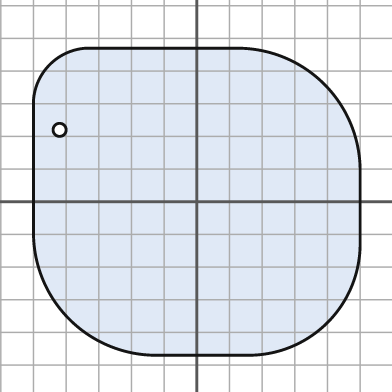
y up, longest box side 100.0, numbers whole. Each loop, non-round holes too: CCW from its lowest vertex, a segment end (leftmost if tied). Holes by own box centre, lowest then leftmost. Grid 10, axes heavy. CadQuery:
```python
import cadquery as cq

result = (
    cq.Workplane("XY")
    .moveTo(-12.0, -47.0)
    .lineTo(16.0, -47.0)
    .threePointArc((40.0, -37.0), (50.0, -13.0))
    .lineTo(50.0, 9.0)
    .threePointArc((39.0, 36.0), (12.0, 47.0))
    .lineTo(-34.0, 47.0)
    .threePointArc((-45.0, 42.0), (-50.0, 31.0))
    .lineTo(-50.0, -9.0)
    .threePointArc((-39.0, -36.0), (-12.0, -47.0))
    .close()
    .moveTo(-42.0, 22.0)
    .circle(2.0)
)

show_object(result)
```